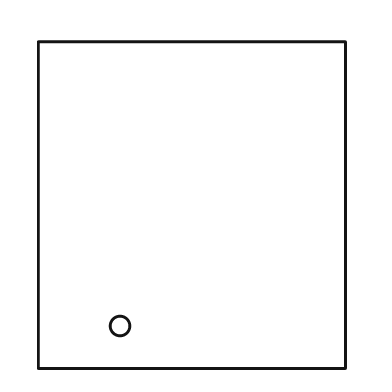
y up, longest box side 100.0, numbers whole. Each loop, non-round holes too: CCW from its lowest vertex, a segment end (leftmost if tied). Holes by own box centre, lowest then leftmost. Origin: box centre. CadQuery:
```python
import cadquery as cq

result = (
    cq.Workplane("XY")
    .moveTo(-47.0, -50.0)
    .lineTo(47.0, -50.0)
    .lineTo(47.0, 50.0)
    .lineTo(-47.0, 50.0)
    .close()
    .moveTo(-22.0, -37.0)
    .circle(3.0)
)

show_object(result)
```